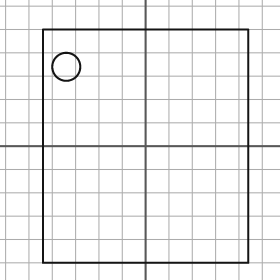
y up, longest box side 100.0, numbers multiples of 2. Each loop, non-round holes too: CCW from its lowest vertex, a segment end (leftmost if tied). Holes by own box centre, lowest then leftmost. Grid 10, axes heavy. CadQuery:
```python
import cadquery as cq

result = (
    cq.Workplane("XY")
    .moveTo(-44.0, -50.0)
    .lineTo(44.0, -50.0)
    .lineTo(44.0, 50.0)
    .lineTo(-44.0, 50.0)
    .close()
    .moveTo(-34.0, 34.0)
    .circle(6.0)
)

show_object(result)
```